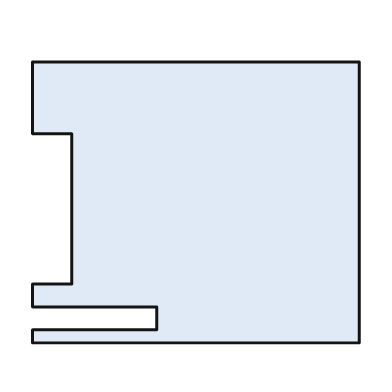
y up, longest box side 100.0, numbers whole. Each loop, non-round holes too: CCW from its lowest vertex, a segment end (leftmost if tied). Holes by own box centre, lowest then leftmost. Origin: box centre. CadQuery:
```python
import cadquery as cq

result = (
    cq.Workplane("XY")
    .moveTo(-50.0, -43.0)
    .lineTo(50.0, -43.0)
    .lineTo(50.0, 43.0)
    .lineTo(-50.0, 43.0)
    .lineTo(-50.0, 21.0)
    .lineTo(-38.0, 21.0)
    .lineTo(-38.0, -25.0)
    .lineTo(-50.0, -25.0)
    .lineTo(-50.0, -32.0)
    .lineTo(-12.0, -32.0)
    .lineTo(-12.0, -39.0)
    .lineTo(-50.0, -39.0)
    .close()
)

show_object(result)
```